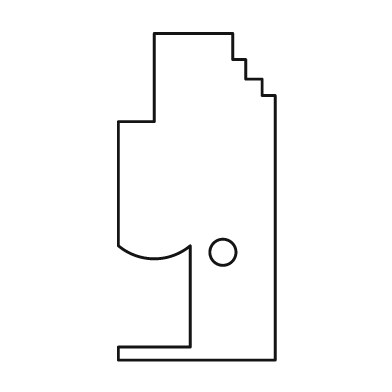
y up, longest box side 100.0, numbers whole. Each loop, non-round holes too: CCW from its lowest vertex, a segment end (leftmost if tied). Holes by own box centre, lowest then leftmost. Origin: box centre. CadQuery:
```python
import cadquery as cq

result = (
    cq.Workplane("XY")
    .moveTo(-24.0, -50.0)
    .lineTo(24.0, -50.0)
    .lineTo(24.0, 31.0)
    .lineTo(20.0, 31.0)
    .lineTo(20.0, 36.0)
    .lineTo(15.0, 36.0)
    .lineTo(15.0, 42.0)
    .lineTo(11.0, 42.0)
    .lineTo(11.0, 50.0)
    .lineTo(-13.0, 50.0)
    .lineTo(-13.0, 23.0)
    .lineTo(-24.0, 23.0)
    .lineTo(-24.0, -15.0)
    .threePointArc((-13.0, -19.0), (-2.0, -15.0))
    .lineTo(-2.0, -46.0)
    .lineTo(-24.0, -46.0)
    .close()
    .moveTo(8.0, -17.0)
    .circle(4.0)
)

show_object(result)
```